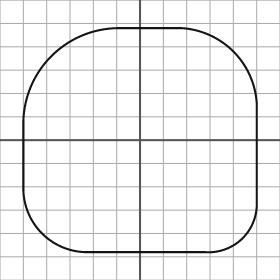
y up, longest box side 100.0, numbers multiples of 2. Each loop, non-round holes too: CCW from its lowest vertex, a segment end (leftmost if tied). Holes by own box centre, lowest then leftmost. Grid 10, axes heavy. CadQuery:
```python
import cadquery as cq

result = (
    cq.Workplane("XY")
    .moveTo(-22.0, -48.0)
    .lineTo(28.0, -48.0)
    .threePointArc((44.0, -42.0), (50.0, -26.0))
    .lineTo(50.0, 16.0)
    .threePointArc((40.0, 38.0), (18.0, 48.0))
    .lineTo(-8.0, 48.0)
    .threePointArc((-38.0, 36.0), (-50.0, 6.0))
    .lineTo(-50.0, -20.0)
    .threePointArc((-42.0, -40.0), (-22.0, -48.0))
    .close()
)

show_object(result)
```